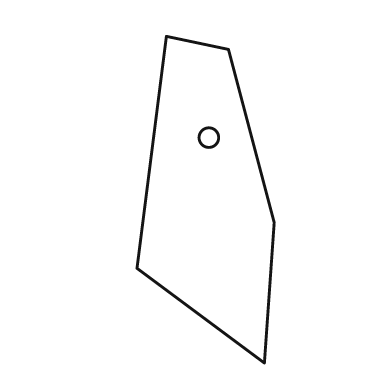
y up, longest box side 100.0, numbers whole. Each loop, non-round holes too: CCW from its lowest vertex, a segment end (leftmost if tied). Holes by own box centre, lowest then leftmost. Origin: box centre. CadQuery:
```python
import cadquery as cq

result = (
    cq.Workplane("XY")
    .moveTo(18.0, -50.0)
    .lineTo(21.0, -7.0)
    .lineTo(7.0, 46.0)
    .lineTo(-12.0, 50.0)
    .lineTo(-21.0, -21.0)
    .close()
    .moveTo(1.0, 19.0)
    .circle(3.0)
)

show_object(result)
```